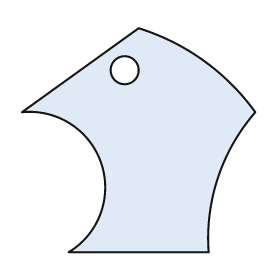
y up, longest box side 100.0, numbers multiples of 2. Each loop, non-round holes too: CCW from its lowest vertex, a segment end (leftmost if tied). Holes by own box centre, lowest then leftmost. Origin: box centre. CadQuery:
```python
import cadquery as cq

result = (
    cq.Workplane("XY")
    .moveTo(-30.0, -48.0)
    .lineTo(30.0, -48.0)
    .threePointArc((34.0, -16.0), (50.0, 12.0))
    .threePointArc((28.0, 34.0), (0.0, 48.0))
    .lineTo(-50.0, 12.0)
    .threePointArc((-16.0, -10.0), (-30.0, -48.0))
    .close()
    .moveTo(-6.0, 30.0)
    .circle(6.0)
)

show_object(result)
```